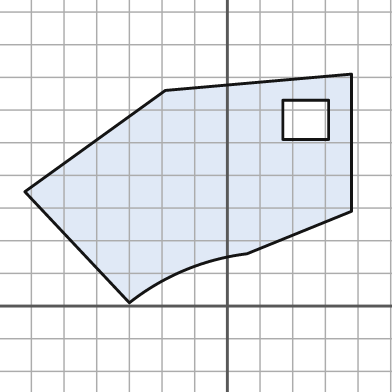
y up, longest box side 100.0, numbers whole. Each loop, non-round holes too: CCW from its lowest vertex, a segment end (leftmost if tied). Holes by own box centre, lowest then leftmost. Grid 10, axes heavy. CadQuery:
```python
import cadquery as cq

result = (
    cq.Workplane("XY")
    .moveTo(-30.0, 1.0)
    .threePointArc((-13.0, 11.0), (6.0, 16.0))
    .lineTo(38.0, 29.0)
    .lineTo(38.0, 71.0)
    .lineTo(-19.0, 66.0)
    .lineTo(-62.0, 35.0)
    .close()
    .moveTo(17.0, 51.0)
    .lineTo(31.0, 51.0)
    .lineTo(31.0, 63.0)
    .lineTo(17.0, 63.0)
    .close()
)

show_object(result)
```